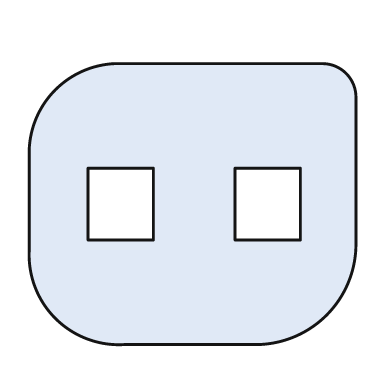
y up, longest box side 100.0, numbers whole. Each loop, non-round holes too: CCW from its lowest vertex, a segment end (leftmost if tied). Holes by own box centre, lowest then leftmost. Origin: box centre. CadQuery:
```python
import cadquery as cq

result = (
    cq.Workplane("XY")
    .moveTo(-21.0, -43.0)
    .lineTo(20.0, -43.0)
    .threePointArc((41.0, -34.0), (50.0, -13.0))
    .lineTo(50.0, 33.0)
    .threePointArc((47.0, 40.0), (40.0, 43.0))
    .lineTo(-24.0, 43.0)
    .threePointArc((-42.0, 35.0), (-50.0, 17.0))
    .lineTo(-50.0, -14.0)
    .threePointArc((-42.0, -35.0), (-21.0, -43.0))
    .close()
    .moveTo(-32.0, -11.0)
    .lineTo(-12.0, -11.0)
    .lineTo(-12.0, 11.0)
    .lineTo(-32.0, 11.0)
    .close()
    .moveTo(13.0, -11.0)
    .lineTo(33.0, -11.0)
    .lineTo(33.0, 11.0)
    .lineTo(13.0, 11.0)
    .close()
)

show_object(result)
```